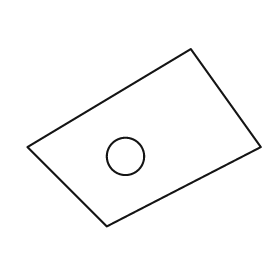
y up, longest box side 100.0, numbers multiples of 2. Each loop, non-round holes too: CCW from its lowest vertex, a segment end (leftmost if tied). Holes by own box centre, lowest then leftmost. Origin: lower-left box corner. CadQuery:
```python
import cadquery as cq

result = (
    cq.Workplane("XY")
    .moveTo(34.0, 0.0)
    .lineTo(100.0, 34.0)
    .lineTo(70.0, 76.0)
    .lineTo(0.0, 34.0)
    .close()
    .moveTo(42.0, 30.0)
    .circle(8.0)
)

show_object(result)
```